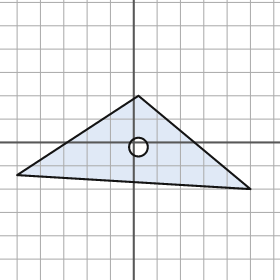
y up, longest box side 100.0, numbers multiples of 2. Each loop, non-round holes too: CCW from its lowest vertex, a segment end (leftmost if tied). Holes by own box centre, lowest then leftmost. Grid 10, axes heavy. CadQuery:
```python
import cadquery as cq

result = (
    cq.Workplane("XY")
    .moveTo(50.0, -20.0)
    .lineTo(2.0, 20.0)
    .lineTo(-50.0, -14.0)
    .close()
    .moveTo(2.0, -2.0)
    .circle(4.0)
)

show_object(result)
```